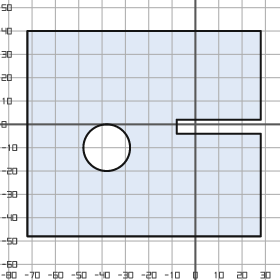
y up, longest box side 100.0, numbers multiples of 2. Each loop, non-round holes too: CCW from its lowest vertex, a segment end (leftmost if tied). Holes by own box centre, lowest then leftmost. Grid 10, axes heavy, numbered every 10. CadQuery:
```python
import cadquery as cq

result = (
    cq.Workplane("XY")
    .moveTo(-72.0, -48.0)
    .lineTo(28.0, -48.0)
    .lineTo(28.0, -4.0)
    .lineTo(-8.0, -4.0)
    .lineTo(-8.0, 2.0)
    .lineTo(28.0, 2.0)
    .lineTo(28.0, 40.0)
    .lineTo(-72.0, 40.0)
    .close()
    .moveTo(-38.0, -10.0)
    .circle(10.0)
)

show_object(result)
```